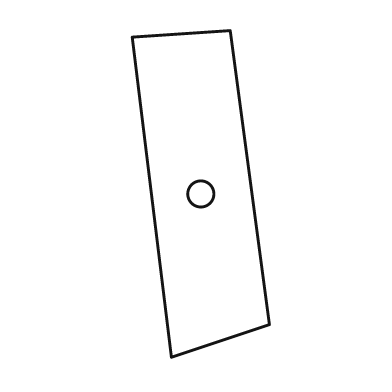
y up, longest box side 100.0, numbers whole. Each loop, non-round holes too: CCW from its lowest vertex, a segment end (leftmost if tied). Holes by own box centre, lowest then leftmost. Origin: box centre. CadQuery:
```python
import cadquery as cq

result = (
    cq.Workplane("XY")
    .moveTo(-9.0, -50.0)
    .lineTo(21.0, -40.0)
    .lineTo(9.0, 50.0)
    .lineTo(-21.0, 48.0)
    .close()
    .moveTo(0.0, 0.0)
    .circle(4.0)
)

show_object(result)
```